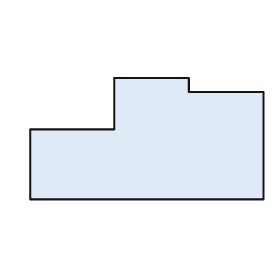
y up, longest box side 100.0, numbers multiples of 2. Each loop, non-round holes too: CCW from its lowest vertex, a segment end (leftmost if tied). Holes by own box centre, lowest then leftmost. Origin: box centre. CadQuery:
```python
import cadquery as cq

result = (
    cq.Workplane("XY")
    .moveTo(-50.0, -26.0)
    .lineTo(50.0, -26.0)
    .lineTo(50.0, 20.0)
    .lineTo(18.0, 20.0)
    .lineTo(18.0, 26.0)
    .lineTo(-14.0, 26.0)
    .lineTo(-14.0, 4.0)
    .lineTo(-50.0, 4.0)
    .close()
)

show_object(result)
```